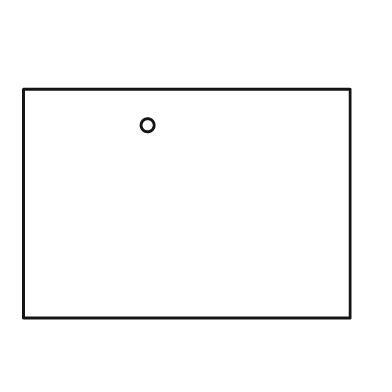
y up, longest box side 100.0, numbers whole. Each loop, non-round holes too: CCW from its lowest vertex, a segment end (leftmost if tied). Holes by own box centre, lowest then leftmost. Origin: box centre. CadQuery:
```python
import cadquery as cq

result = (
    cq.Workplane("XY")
    .moveTo(-50.0, -35.0)
    .lineTo(50.0, -35.0)
    .lineTo(50.0, 35.0)
    .lineTo(-50.0, 35.0)
    .close()
    .moveTo(-12.0, 24.0)
    .circle(2.0)
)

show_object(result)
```